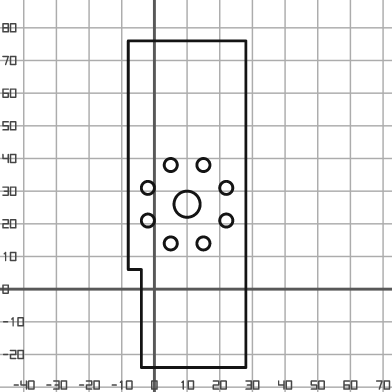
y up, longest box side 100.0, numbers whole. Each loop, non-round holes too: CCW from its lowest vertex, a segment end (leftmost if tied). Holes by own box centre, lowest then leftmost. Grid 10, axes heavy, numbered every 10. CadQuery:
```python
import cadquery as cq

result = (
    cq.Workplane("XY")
    .moveTo(-4.0, -24.0)
    .lineTo(28.0, -24.0)
    .lineTo(28.0, 76.0)
    .lineTo(-8.0, 76.0)
    .lineTo(-8.0, 6.0)
    .lineTo(-4.0, 6.0)
    .close()
    .moveTo(5.0, 14.0)
    .circle(2.0)
    .moveTo(15.0, 14.0)
    .circle(2.0)
    .moveTo(-2.0, 21.0)
    .circle(2.0)
    .moveTo(22.0, 21.0)
    .circle(2.0)
    .moveTo(10.0, 26.0)
    .circle(4.0)
    .moveTo(-2.0, 31.0)
    .circle(2.0)
    .moveTo(22.0, 31.0)
    .circle(2.0)
    .moveTo(5.0, 38.0)
    .circle(2.0)
    .moveTo(15.0, 38.0)
    .circle(2.0)
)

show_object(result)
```